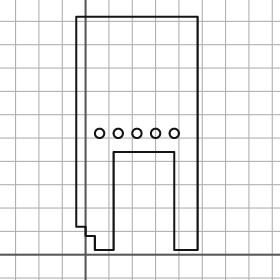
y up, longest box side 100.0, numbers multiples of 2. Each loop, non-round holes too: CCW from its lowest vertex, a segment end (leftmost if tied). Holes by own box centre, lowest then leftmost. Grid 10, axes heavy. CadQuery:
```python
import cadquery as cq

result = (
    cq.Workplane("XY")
    .moveTo(4.0, 2.0)
    .lineTo(12.0, 2.0)
    .lineTo(12.0, 44.0)
    .lineTo(38.0, 44.0)
    .lineTo(38.0, 2.0)
    .lineTo(48.0, 2.0)
    .lineTo(48.0, 102.0)
    .lineTo(-4.0, 102.0)
    .lineTo(-4.0, 12.0)
    .lineTo(0.0, 12.0)
    .lineTo(0.0, 8.0)
    .lineTo(4.0, 8.0)
    .close()
    .moveTo(6.0, 52.0)
    .circle(2.0)
    .moveTo(14.0, 52.0)
    .circle(2.0)
    .moveTo(22.0, 52.0)
    .circle(2.0)
    .moveTo(30.0, 52.0)
    .circle(2.0)
    .moveTo(38.0, 52.0)
    .circle(2.0)
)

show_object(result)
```